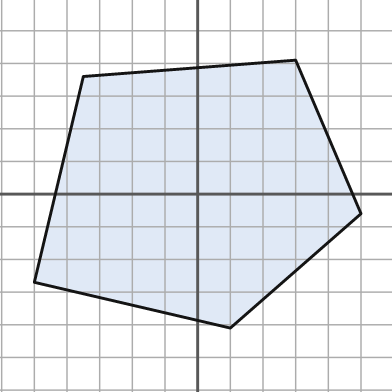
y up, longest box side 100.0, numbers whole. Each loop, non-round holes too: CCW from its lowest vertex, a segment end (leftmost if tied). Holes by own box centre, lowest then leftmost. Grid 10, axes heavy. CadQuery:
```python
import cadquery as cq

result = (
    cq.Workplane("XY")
    .moveTo(10.0, -41.0)
    .lineTo(50.0, -6.0)
    .lineTo(30.0, 41.0)
    .lineTo(-35.0, 36.0)
    .lineTo(-50.0, -27.0)
    .close()
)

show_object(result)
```